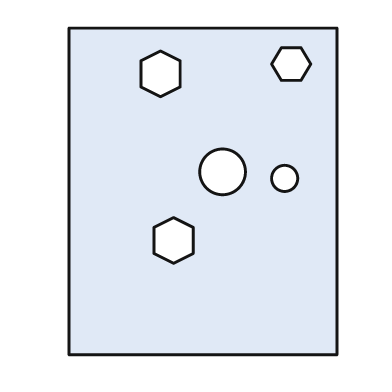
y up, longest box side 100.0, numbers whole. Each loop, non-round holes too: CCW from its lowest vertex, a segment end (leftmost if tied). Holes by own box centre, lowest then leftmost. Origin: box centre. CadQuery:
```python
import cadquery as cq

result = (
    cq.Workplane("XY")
    .moveTo(-41.0, -50.0)
    .lineTo(41.0, -50.0)
    .lineTo(41.0, 50.0)
    .lineTo(-41.0, 50.0)
    .close()
    .moveTo(-9.0, -22.0)
    .lineTo(-3.0, -19.0)
    .lineTo(-3.0, -11.0)
    .lineTo(-9.0, -8.0)
    .lineTo(-15.0, -11.0)
    .lineTo(-15.0, -19.0)
    .close()
    .moveTo(25.0, 4.0)
    .circle(4.0)
    .moveTo(6.0, 6.0)
    .circle(7.0)
    .moveTo(-13.0, 29.0)
    .lineTo(-7.0, 32.0)
    .lineTo(-7.0, 40.0)
    .lineTo(-13.0, 43.0)
    .lineTo(-19.0, 40.0)
    .lineTo(-19.0, 32.0)
    .close()
    .moveTo(24.0, 34.0)
    .lineTo(30.0, 34.0)
    .lineTo(33.0, 39.0)
    .lineTo(30.0, 44.0)
    .lineTo(24.0, 44.0)
    .lineTo(21.0, 39.0)
    .close()
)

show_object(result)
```